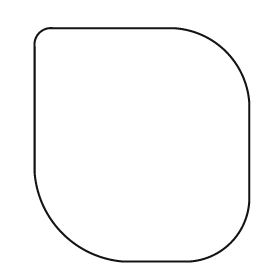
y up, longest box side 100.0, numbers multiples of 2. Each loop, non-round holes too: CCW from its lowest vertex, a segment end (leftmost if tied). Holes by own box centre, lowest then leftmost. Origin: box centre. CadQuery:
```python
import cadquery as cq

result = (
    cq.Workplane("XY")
    .moveTo(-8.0, -50.0)
    .lineTo(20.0, -50.0)
    .threePointArc((38.0, -42.0), (46.0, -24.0))
    .lineTo(46.0, 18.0)
    .threePointArc((36.0, 40.0), (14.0, 50.0))
    .lineTo(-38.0, 50.0)
    .threePointArc((-44.0, 48.0), (-46.0, 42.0))
    .lineTo(-46.0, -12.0)
    .threePointArc((-34.0, -38.0), (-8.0, -50.0))
    .close()
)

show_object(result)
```